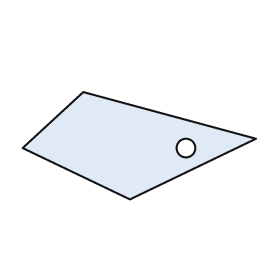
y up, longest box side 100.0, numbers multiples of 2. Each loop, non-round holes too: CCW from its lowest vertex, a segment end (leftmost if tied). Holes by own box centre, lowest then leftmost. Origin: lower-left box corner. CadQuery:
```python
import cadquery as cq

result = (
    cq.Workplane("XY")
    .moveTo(46.0, 0.0)
    .lineTo(100.0, 26.0)
    .lineTo(26.0, 46.0)
    .lineTo(0.0, 22.0)
    .close()
    .moveTo(70.0, 22.0)
    .circle(4.0)
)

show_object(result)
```